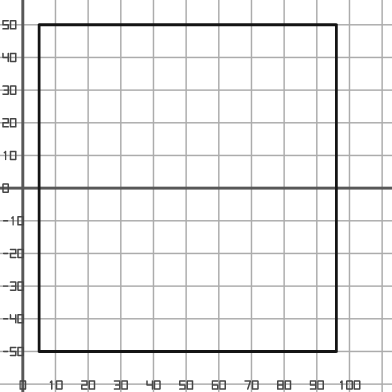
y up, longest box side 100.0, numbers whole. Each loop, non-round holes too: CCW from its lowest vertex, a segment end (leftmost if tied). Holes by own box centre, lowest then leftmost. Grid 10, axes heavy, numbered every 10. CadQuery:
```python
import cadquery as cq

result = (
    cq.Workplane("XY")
    .moveTo(5.0, -50.0)
    .lineTo(96.0, -50.0)
    .lineTo(96.0, 50.0)
    .lineTo(5.0, 50.0)
    .close()
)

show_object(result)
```